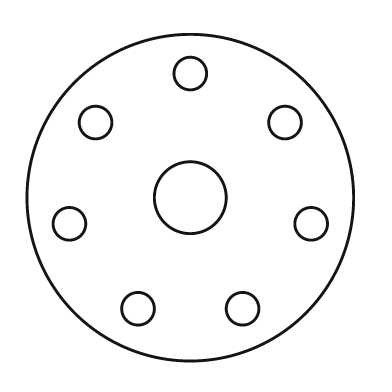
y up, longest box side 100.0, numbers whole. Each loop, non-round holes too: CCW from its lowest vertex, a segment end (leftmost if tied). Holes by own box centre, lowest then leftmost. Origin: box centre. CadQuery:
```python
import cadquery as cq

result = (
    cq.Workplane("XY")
    .moveTo(0.0, 0.0)
    .circle(50.0)
    .moveTo(-16.0, -34.0)
    .circle(5.0)
    .moveTo(16.0, -34.0)
    .circle(5.0)
    .moveTo(-37.0, -8.0)
    .circle(5.0)
    .moveTo(37.0, -8.0)
    .circle(5.0)
    .moveTo(0.0, 0.0)
    .circle(11.0)
    .moveTo(-29.0, 23.0)
    .circle(5.0)
    .moveTo(29.0, 23.0)
    .circle(5.0)
    .moveTo(0.0, 38.0)
    .circle(5.0)
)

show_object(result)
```